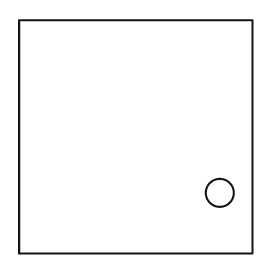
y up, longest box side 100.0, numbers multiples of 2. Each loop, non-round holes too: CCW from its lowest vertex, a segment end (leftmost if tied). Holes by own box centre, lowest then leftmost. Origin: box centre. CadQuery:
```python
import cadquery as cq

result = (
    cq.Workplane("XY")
    .moveTo(-50.0, -50.0)
    .lineTo(50.0, -50.0)
    .lineTo(50.0, 50.0)
    .lineTo(-50.0, 50.0)
    .close()
    .moveTo(36.0, -24.0)
    .circle(6.0)
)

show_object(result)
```